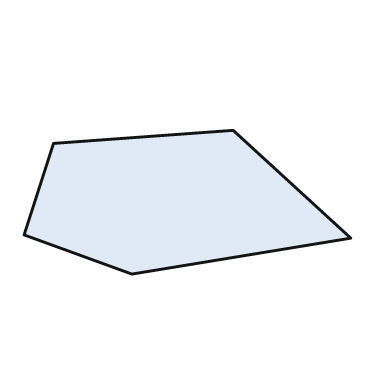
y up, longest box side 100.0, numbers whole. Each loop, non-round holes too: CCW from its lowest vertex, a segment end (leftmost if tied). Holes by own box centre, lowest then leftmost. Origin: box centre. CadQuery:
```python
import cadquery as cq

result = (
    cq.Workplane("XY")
    .moveTo(-17.0, -22.0)
    .lineTo(50.0, -11.0)
    .lineTo(14.0, 22.0)
    .lineTo(-41.0, 18.0)
    .lineTo(-50.0, -10.0)
    .close()
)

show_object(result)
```